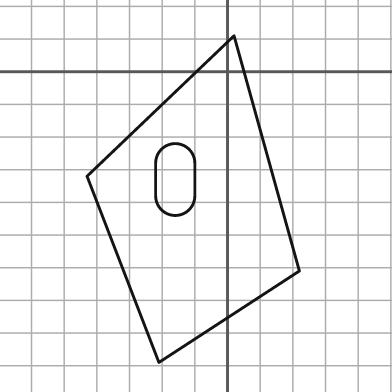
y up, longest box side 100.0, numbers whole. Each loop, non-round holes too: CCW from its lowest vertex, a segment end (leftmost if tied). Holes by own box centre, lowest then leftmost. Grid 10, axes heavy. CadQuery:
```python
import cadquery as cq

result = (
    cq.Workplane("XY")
    .moveTo(-21.0, -89.0)
    .lineTo(22.0, -61.0)
    .lineTo(2.0, 11.0)
    .lineTo(-43.0, -32.0)
    .close()
    .moveTo(-22.0, -38.0)
    .threePointArc((-16.0, -44.0), (-10.0, -38.0))
    .lineTo(-10.0, -28.0)
    .threePointArc((-16.0, -22.0), (-22.0, -28.0))
    .close()
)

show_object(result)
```